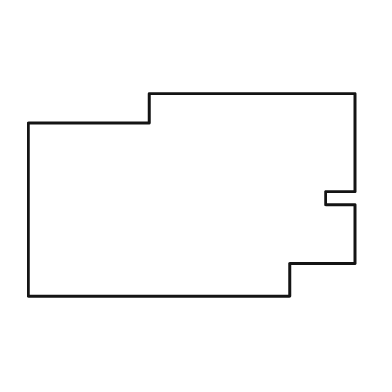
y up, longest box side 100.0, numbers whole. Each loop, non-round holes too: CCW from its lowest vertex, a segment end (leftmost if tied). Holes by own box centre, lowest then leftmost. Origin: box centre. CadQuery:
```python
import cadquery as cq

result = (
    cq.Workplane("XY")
    .moveTo(-50.0, -31.0)
    .lineTo(30.0, -31.0)
    .lineTo(30.0, -21.0)
    .lineTo(50.0, -21.0)
    .lineTo(50.0, -3.0)
    .lineTo(41.0, -3.0)
    .lineTo(41.0, 1.0)
    .lineTo(50.0, 1.0)
    .lineTo(50.0, 31.0)
    .lineTo(-13.0, 31.0)
    .lineTo(-13.0, 22.0)
    .lineTo(-50.0, 22.0)
    .close()
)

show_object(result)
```